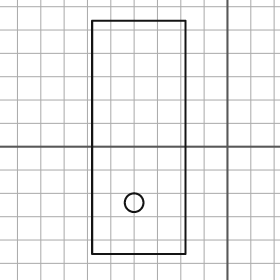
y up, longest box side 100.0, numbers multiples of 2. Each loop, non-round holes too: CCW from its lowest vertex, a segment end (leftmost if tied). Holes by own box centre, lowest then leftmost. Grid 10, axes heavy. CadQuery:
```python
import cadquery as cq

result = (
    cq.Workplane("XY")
    .moveTo(-58.0, -46.0)
    .lineTo(-18.0, -46.0)
    .lineTo(-18.0, 54.0)
    .lineTo(-58.0, 54.0)
    .close()
    .moveTo(-40.0, -24.0)
    .circle(4.0)
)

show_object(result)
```